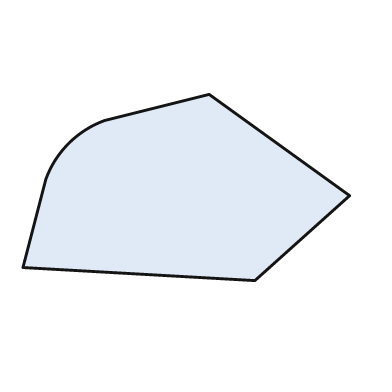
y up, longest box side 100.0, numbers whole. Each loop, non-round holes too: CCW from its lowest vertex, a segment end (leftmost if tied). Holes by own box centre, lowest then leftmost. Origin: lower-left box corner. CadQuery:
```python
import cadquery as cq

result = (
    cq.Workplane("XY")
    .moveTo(71.0, 0.0)
    .lineTo(100.0, 26.0)
    .lineTo(57.0, 57.0)
    .lineTo(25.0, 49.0)
    .threePointArc((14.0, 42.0), (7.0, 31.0))
    .lineTo(0.0, 4.0)
    .close()
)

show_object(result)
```